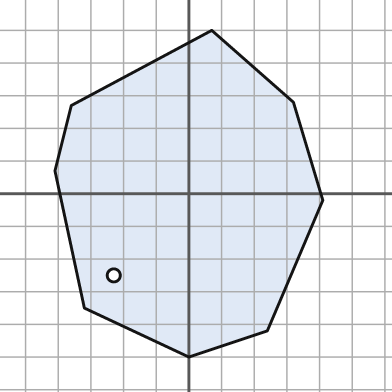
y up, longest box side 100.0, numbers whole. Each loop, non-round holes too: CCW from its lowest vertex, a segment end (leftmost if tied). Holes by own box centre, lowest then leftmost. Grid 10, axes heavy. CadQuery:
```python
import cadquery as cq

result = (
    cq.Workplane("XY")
    .moveTo(0.0, -50.0)
    .lineTo(24.0, -42.0)
    .lineTo(41.0, -2.0)
    .lineTo(32.0, 28.0)
    .lineTo(7.0, 50.0)
    .lineTo(-36.0, 27.0)
    .lineTo(-41.0, 7.0)
    .lineTo(-32.0, -35.0)
    .close()
    .moveTo(-23.0, -25.0)
    .circle(2.0)
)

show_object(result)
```